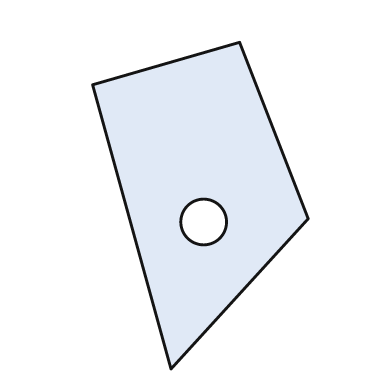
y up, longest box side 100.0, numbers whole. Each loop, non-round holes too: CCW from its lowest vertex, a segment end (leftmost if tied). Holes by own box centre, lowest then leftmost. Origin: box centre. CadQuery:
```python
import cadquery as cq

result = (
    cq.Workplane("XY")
    .moveTo(-9.0, -50.0)
    .lineTo(33.0, -4.0)
    .lineTo(12.0, 50.0)
    .lineTo(-33.0, 37.0)
    .close()
    .moveTo(1.0, -5.0)
    .circle(7.0)
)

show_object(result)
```